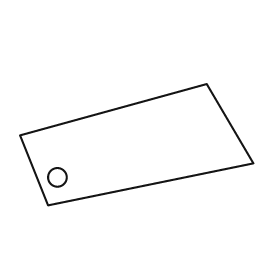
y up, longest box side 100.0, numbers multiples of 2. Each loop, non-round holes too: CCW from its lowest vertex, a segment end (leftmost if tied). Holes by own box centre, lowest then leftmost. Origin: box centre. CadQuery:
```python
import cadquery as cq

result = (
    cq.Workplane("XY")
    .moveTo(-38.0, -26.0)
    .lineTo(50.0, -8.0)
    .lineTo(30.0, 26.0)
    .lineTo(-50.0, 4.0)
    .close()
    .moveTo(-34.0, -14.0)
    .circle(4.0)
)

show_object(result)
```